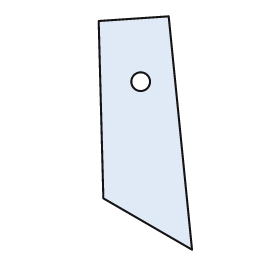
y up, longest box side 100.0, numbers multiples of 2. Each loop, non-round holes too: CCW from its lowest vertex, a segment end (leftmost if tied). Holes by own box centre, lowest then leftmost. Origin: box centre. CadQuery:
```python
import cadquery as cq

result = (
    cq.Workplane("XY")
    .moveTo(20.0, -50.0)
    .lineTo(10.0, 50.0)
    .lineTo(-20.0, 48.0)
    .lineTo(-18.0, -28.0)
    .close()
    .moveTo(-2.0, 22.0)
    .circle(4.0)
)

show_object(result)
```